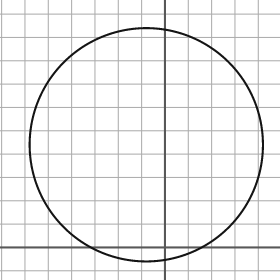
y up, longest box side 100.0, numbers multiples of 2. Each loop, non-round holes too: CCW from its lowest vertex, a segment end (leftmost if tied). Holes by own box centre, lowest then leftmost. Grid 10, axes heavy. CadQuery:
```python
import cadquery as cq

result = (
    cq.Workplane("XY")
    .moveTo(-8.0, 44.0)
    .circle(50.0)
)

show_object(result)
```